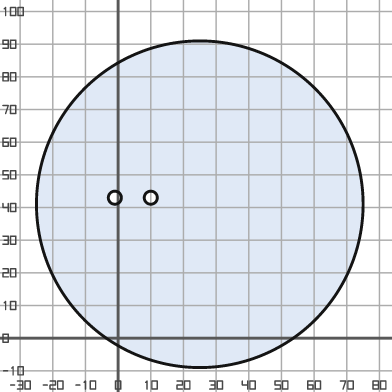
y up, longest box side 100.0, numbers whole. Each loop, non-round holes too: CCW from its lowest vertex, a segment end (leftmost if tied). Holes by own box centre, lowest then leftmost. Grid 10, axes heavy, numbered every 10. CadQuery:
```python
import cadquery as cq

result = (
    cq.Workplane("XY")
    .moveTo(25.0, 41.0)
    .circle(50.0)
    .moveTo(-1.0, 43.0)
    .circle(2.0)
    .moveTo(10.0, 43.0)
    .circle(2.0)
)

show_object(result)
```